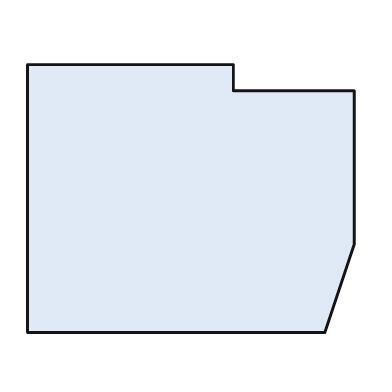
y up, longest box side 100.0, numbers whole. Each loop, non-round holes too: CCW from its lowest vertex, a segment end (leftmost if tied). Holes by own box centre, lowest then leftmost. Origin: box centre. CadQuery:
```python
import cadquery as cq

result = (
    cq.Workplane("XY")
    .moveTo(-50.0, -41.0)
    .lineTo(41.0, -41.0)
    .lineTo(50.0, -14.0)
    .lineTo(50.0, 33.0)
    .lineTo(13.0, 33.0)
    .lineTo(13.0, 41.0)
    .lineTo(-50.0, 41.0)
    .close()
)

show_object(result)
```